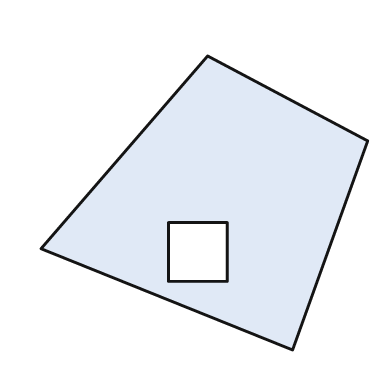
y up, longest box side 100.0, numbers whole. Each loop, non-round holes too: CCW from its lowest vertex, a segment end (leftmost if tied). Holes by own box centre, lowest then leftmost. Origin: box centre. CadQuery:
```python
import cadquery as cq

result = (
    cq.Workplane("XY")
    .moveTo(27.0, -45.0)
    .lineTo(50.0, 19.0)
    .lineTo(1.0, 45.0)
    .lineTo(-50.0, -14.0)
    .close()
    .moveTo(-11.0, -24.0)
    .lineTo(7.0, -24.0)
    .lineTo(7.0, -6.0)
    .lineTo(-11.0, -6.0)
    .close()
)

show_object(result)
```